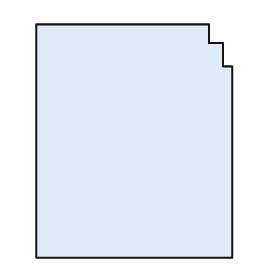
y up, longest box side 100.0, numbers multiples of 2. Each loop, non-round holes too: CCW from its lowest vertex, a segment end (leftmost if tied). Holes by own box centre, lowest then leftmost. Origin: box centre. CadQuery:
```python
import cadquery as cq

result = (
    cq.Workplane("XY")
    .moveTo(-42.0, -50.0)
    .lineTo(42.0, -50.0)
    .lineTo(42.0, 32.0)
    .lineTo(38.0, 32.0)
    .lineTo(38.0, 42.0)
    .lineTo(32.0, 42.0)
    .lineTo(32.0, 50.0)
    .lineTo(-42.0, 50.0)
    .close()
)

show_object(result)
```